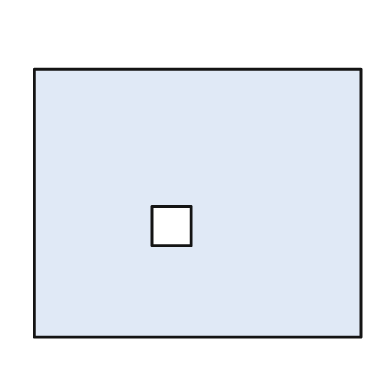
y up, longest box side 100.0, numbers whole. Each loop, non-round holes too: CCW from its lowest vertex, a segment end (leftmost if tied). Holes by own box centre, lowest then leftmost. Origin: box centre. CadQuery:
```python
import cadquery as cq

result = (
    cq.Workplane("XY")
    .moveTo(-50.0, -41.0)
    .lineTo(50.0, -41.0)
    .lineTo(50.0, 41.0)
    .lineTo(-50.0, 41.0)
    .close()
    .moveTo(-14.0, -13.0)
    .lineTo(-2.0, -13.0)
    .lineTo(-2.0, -1.0)
    .lineTo(-14.0, -1.0)
    .close()
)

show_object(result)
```